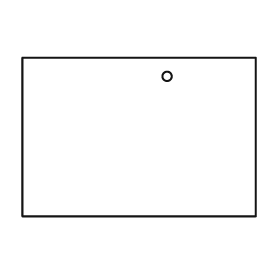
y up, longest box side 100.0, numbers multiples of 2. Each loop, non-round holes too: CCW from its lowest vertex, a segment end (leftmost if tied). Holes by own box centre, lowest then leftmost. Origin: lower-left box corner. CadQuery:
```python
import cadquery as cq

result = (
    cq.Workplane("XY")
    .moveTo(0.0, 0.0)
    .lineTo(100.0, 0.0)
    .lineTo(100.0, 68.0)
    .lineTo(0.0, 68.0)
    .close()
    .moveTo(62.0, 60.0)
    .circle(2.0)
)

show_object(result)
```